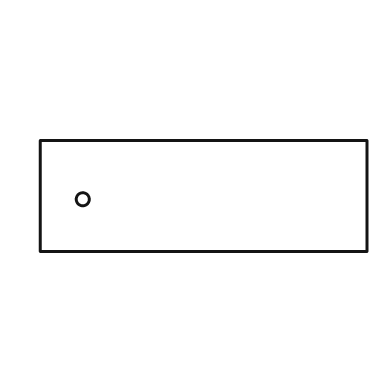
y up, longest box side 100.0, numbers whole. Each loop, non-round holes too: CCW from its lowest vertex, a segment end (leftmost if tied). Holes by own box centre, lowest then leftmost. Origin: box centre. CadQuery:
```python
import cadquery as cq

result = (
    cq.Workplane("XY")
    .moveTo(-50.0, -17.0)
    .lineTo(50.0, -17.0)
    .lineTo(50.0, 17.0)
    .lineTo(-50.0, 17.0)
    .close()
    .moveTo(-37.0, -1.0)
    .circle(2.0)
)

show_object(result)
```